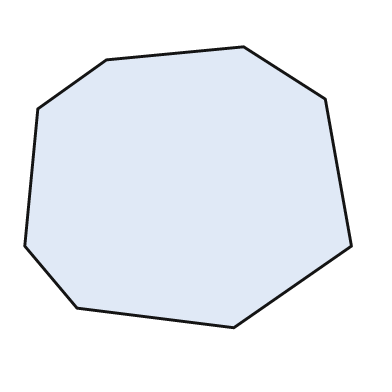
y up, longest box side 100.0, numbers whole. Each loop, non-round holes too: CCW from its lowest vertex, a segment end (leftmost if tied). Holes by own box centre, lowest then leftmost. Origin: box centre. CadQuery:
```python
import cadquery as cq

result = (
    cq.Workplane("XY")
    .moveTo(14.0, -43.0)
    .lineTo(50.0, -18.0)
    .lineTo(42.0, 27.0)
    .lineTo(17.0, 43.0)
    .lineTo(-25.0, 39.0)
    .lineTo(-46.0, 24.0)
    .lineTo(-50.0, -18.0)
    .lineTo(-34.0, -37.0)
    .close()
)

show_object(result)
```